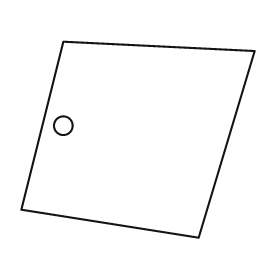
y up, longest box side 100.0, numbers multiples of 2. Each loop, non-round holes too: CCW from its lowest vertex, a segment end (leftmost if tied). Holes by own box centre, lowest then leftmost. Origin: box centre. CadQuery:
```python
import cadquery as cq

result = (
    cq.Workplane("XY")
    .moveTo(26.0, -42.0)
    .lineTo(50.0, 38.0)
    .lineTo(-32.0, 42.0)
    .lineTo(-50.0, -30.0)
    .close()
    .moveTo(-32.0, 6.0)
    .circle(4.0)
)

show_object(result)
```